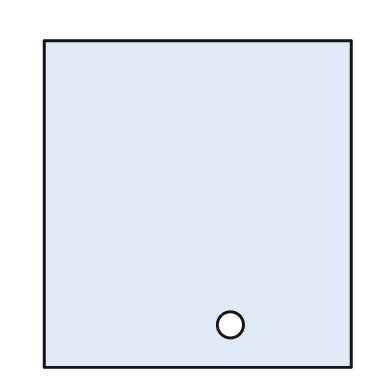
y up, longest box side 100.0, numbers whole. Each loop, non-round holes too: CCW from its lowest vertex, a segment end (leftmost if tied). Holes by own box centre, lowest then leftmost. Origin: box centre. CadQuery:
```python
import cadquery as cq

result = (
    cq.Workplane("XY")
    .moveTo(-47.0, -50.0)
    .lineTo(47.0, -50.0)
    .lineTo(47.0, 50.0)
    .lineTo(-47.0, 50.0)
    .close()
    .moveTo(10.0, -37.0)
    .circle(4.0)
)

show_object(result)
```